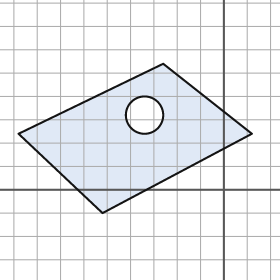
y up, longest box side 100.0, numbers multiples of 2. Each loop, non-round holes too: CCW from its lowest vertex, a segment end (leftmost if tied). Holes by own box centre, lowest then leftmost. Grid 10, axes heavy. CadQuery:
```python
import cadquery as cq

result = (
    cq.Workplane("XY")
    .moveTo(-52.0, -10.0)
    .lineTo(12.0, 24.0)
    .lineTo(-26.0, 54.0)
    .lineTo(-88.0, 24.0)
    .close()
    .moveTo(-34.0, 32.0)
    .circle(8.0)
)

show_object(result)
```